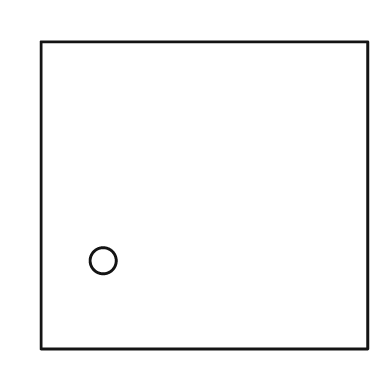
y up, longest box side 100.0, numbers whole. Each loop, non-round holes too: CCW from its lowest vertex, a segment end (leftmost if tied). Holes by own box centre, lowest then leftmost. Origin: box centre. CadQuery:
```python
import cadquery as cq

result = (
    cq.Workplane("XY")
    .moveTo(-50.0, -47.0)
    .lineTo(50.0, -47.0)
    .lineTo(50.0, 47.0)
    .lineTo(-50.0, 47.0)
    .close()
    .moveTo(-31.0, -20.0)
    .circle(4.0)
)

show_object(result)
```